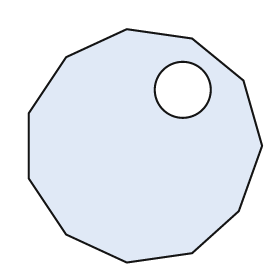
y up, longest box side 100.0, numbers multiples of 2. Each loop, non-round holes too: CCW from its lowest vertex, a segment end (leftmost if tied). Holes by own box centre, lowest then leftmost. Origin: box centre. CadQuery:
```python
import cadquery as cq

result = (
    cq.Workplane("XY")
    .moveTo(-8.0, -50.0)
    .lineTo(20.0, -46.0)
    .lineTo(40.0, -28.0)
    .lineTo(50.0, 0.0)
    .lineTo(42.0, 28.0)
    .lineTo(20.0, 46.0)
    .lineTo(-8.0, 50.0)
    .lineTo(-34.0, 38.0)
    .lineTo(-50.0, 14.0)
    .lineTo(-50.0, -14.0)
    .lineTo(-34.0, -38.0)
    .close()
    .moveTo(16.0, 24.0)
    .circle(12.0)
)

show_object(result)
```